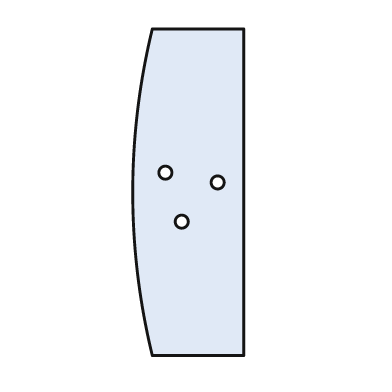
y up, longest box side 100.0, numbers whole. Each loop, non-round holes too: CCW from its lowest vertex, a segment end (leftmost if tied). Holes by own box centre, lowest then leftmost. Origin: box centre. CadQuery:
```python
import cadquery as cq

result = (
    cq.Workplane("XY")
    .moveTo(-11.0, -50.0)
    .lineTo(17.0, -50.0)
    .lineTo(17.0, 50.0)
    .lineTo(-11.0, 50.0)
    .threePointArc((-17.0, 0.0), (-11.0, -50.0))
    .close()
    .moveTo(-2.0, -9.0)
    .circle(2.0)
    .moveTo(9.0, 3.0)
    .circle(2.0)
    .moveTo(-7.0, 6.0)
    .circle(2.0)
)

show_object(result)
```